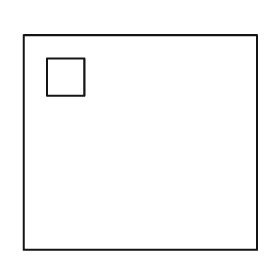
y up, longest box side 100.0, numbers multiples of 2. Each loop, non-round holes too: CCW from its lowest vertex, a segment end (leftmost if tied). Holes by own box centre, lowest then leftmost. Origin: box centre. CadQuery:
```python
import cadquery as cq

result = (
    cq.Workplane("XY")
    .moveTo(-50.0, -46.0)
    .lineTo(50.0, -46.0)
    .lineTo(50.0, 46.0)
    .lineTo(-50.0, 46.0)
    .close()
    .moveTo(-40.0, 20.0)
    .lineTo(-24.0, 20.0)
    .lineTo(-24.0, 36.0)
    .lineTo(-40.0, 36.0)
    .close()
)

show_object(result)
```